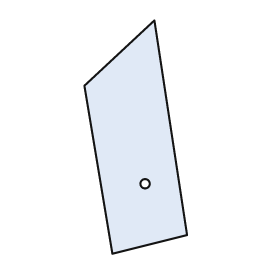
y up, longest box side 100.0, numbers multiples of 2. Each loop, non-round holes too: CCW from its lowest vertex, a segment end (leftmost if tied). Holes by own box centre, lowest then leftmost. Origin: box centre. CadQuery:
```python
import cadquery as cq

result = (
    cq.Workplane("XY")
    .moveTo(-10.0, -50.0)
    .lineTo(22.0, -42.0)
    .lineTo(8.0, 50.0)
    .lineTo(-22.0, 22.0)
    .close()
    .moveTo(4.0, -20.0)
    .circle(2.0)
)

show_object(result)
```